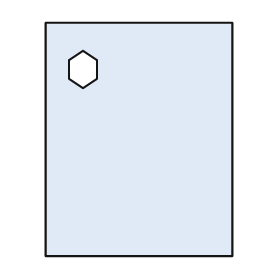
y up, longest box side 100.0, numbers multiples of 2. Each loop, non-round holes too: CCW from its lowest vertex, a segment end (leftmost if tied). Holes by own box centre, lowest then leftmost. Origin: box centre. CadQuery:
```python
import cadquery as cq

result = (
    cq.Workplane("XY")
    .moveTo(-40.0, -50.0)
    .lineTo(40.0, -50.0)
    .lineTo(40.0, 50.0)
    .lineTo(-40.0, 50.0)
    .close()
    .moveTo(-24.0, 22.0)
    .lineTo(-18.0, 26.0)
    .lineTo(-18.0, 34.0)
    .lineTo(-24.0, 38.0)
    .lineTo(-30.0, 34.0)
    .lineTo(-30.0, 26.0)
    .close()
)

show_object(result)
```